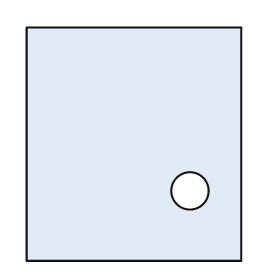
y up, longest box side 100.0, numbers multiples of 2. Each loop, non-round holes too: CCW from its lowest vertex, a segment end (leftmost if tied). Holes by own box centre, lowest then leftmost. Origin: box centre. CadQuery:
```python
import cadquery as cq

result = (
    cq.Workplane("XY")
    .moveTo(-46.0, -50.0)
    .lineTo(46.0, -50.0)
    .lineTo(46.0, 50.0)
    .lineTo(-46.0, 50.0)
    .close()
    .moveTo(24.0, -20.0)
    .circle(8.0)
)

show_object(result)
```